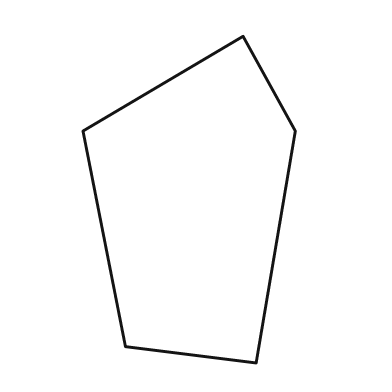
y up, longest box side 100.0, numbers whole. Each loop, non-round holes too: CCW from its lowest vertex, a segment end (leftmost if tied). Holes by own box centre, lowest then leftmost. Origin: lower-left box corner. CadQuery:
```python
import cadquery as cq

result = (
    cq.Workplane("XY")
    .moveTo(53.0, 0.0)
    .lineTo(65.0, 71.0)
    .lineTo(49.0, 100.0)
    .lineTo(0.0, 71.0)
    .lineTo(13.0, 5.0)
    .close()
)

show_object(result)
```